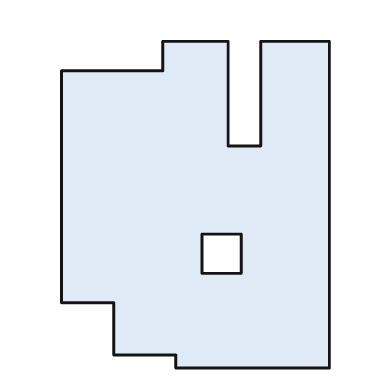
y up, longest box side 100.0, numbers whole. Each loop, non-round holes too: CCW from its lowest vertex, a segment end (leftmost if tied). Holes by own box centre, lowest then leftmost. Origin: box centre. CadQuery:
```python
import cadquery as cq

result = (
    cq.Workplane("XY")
    .moveTo(-6.0, -50.0)
    .lineTo(41.0, -50.0)
    .lineTo(41.0, 50.0)
    .lineTo(20.0, 50.0)
    .lineTo(20.0, 18.0)
    .lineTo(10.0, 18.0)
    .lineTo(10.0, 50.0)
    .lineTo(-10.0, 50.0)
    .lineTo(-10.0, 41.0)
    .lineTo(-41.0, 41.0)
    .lineTo(-41.0, -30.0)
    .lineTo(-25.0, -30.0)
    .lineTo(-25.0, -46.0)
    .lineTo(-6.0, -46.0)
    .close()
    .moveTo(2.0, -21.0)
    .lineTo(14.0, -21.0)
    .lineTo(14.0, -9.0)
    .lineTo(2.0, -9.0)
    .close()
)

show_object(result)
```